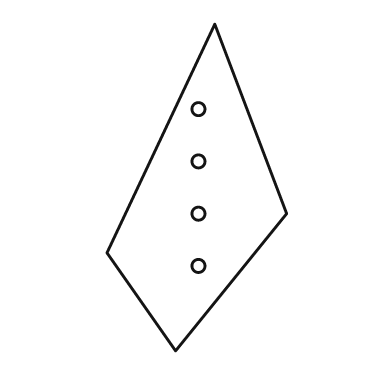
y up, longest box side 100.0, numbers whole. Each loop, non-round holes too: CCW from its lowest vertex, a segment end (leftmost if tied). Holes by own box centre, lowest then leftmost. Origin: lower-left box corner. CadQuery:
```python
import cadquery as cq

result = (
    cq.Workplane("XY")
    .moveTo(21.0, 0.0)
    .lineTo(55.0, 42.0)
    .lineTo(33.0, 100.0)
    .lineTo(0.0, 30.0)
    .close()
    .moveTo(28.0, 26.0)
    .circle(2.0)
    .moveTo(28.0, 42.0)
    .circle(2.0)
    .moveTo(28.0, 58.0)
    .circle(2.0)
    .moveTo(28.0, 74.0)
    .circle(2.0)
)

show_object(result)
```